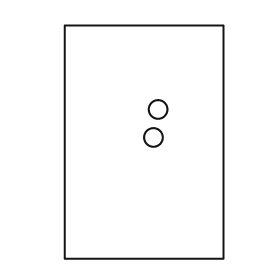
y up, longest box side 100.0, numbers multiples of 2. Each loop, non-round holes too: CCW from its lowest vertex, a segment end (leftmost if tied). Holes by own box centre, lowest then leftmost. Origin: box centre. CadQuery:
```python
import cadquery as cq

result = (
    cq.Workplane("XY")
    .moveTo(-34.0, -50.0)
    .lineTo(34.0, -50.0)
    .lineTo(34.0, 50.0)
    .lineTo(-34.0, 50.0)
    .close()
    .moveTo(4.0, 2.0)
    .circle(4.0)
    .moveTo(6.0, 14.0)
    .circle(4.0)
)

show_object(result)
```